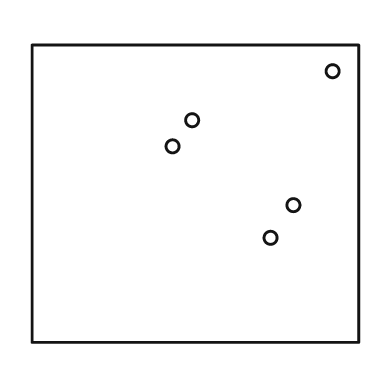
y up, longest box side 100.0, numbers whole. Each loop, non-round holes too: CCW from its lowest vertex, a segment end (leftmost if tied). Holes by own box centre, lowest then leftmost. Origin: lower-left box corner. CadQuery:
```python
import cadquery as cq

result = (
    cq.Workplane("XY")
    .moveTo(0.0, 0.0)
    .lineTo(100.0, 0.0)
    .lineTo(100.0, 91.0)
    .lineTo(0.0, 91.0)
    .close()
    .moveTo(73.0, 32.0)
    .circle(2.0)
    .moveTo(80.0, 42.0)
    .circle(2.0)
    .moveTo(43.0, 60.0)
    .circle(2.0)
    .moveTo(49.0, 68.0)
    .circle(2.0)
    .moveTo(92.0, 83.0)
    .circle(2.0)
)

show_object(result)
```